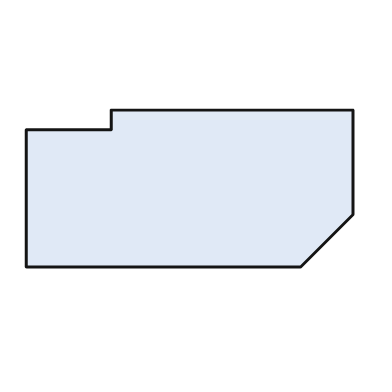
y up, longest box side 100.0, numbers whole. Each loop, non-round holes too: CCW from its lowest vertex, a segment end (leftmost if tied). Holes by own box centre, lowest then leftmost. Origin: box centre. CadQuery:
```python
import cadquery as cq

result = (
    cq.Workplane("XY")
    .moveTo(-50.0, -24.0)
    .lineTo(34.0, -24.0)
    .lineTo(50.0, -8.0)
    .lineTo(50.0, 24.0)
    .lineTo(-24.0, 24.0)
    .lineTo(-24.0, 18.0)
    .lineTo(-50.0, 18.0)
    .close()
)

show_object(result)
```